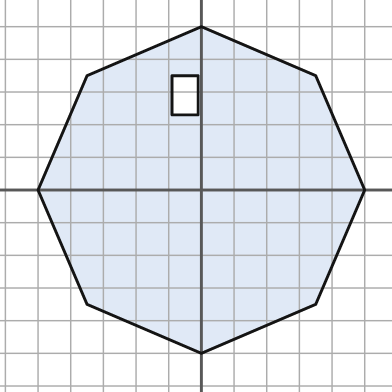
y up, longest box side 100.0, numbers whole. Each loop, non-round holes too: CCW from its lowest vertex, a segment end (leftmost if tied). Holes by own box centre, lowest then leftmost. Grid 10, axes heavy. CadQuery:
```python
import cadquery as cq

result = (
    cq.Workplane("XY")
    .moveTo(0.0, -50.0)
    .lineTo(35.0, -35.0)
    .lineTo(50.0, 0.0)
    .lineTo(35.0, 35.0)
    .lineTo(0.0, 50.0)
    .lineTo(-35.0, 35.0)
    .lineTo(-50.0, 0.0)
    .lineTo(-35.0, -35.0)
    .close()
    .moveTo(-9.0, 23.0)
    .lineTo(-1.0, 23.0)
    .lineTo(-1.0, 35.0)
    .lineTo(-9.0, 35.0)
    .close()
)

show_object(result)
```